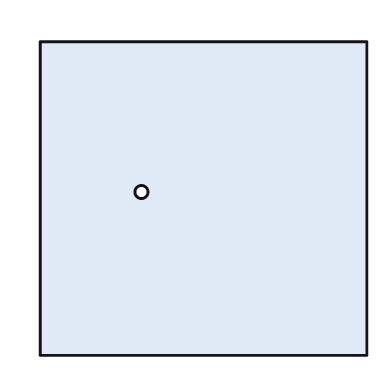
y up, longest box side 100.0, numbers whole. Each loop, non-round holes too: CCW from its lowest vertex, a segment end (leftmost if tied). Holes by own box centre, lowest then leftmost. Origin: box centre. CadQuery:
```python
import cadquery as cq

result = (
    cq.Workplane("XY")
    .moveTo(-50.0, -48.0)
    .lineTo(50.0, -48.0)
    .lineTo(50.0, 48.0)
    .lineTo(-50.0, 48.0)
    .close()
    .moveTo(-19.0, 2.0)
    .circle(2.0)
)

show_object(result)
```